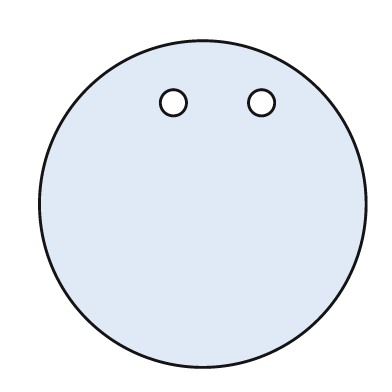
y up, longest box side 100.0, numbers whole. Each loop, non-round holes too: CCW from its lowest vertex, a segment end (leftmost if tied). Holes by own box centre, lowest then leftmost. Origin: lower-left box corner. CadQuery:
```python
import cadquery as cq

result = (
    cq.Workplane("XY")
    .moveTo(50.0, 50.0)
    .circle(50.0)
    .moveTo(41.0, 81.0)
    .circle(4.0)
    .moveTo(68.0, 81.0)
    .circle(4.0)
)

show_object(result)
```